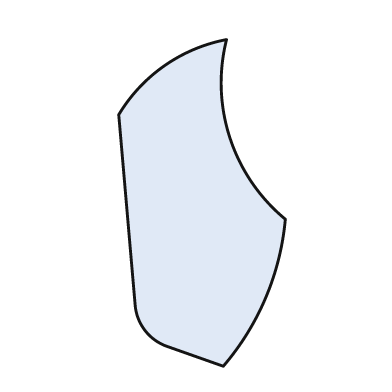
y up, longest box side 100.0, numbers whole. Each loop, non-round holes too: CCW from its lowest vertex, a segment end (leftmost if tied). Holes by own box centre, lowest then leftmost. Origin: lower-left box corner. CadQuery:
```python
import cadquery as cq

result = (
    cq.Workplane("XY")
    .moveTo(32.0, 0.0)
    .threePointArc((45.0, 21.0), (51.0, 45.0))
    .threePointArc((34.0, 70.0), (33.0, 100.0))
    .threePointArc((14.0, 92.0), (0.0, 77.0))
    .lineTo(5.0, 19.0)
    .threePointArc((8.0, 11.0), (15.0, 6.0))
    .close()
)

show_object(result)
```